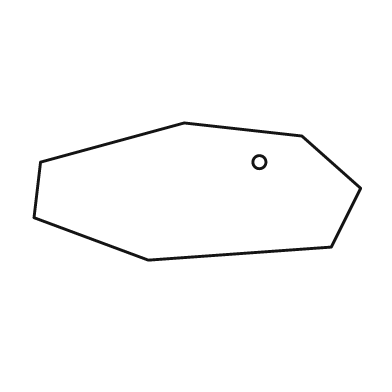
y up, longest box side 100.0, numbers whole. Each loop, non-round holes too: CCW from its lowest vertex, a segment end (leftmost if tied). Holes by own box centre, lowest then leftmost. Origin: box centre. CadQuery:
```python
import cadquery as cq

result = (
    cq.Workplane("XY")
    .moveTo(-15.0, -21.0)
    .lineTo(41.0, -17.0)
    .lineTo(50.0, 1.0)
    .lineTo(32.0, 17.0)
    .lineTo(-4.0, 21.0)
    .lineTo(-48.0, 9.0)
    .lineTo(-50.0, -8.0)
    .close()
    .moveTo(19.0, 9.0)
    .circle(2.0)
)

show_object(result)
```